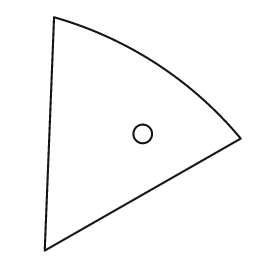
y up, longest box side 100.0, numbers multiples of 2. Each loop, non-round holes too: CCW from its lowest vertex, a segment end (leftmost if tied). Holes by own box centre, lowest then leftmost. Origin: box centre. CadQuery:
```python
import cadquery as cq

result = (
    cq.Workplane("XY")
    .moveTo(-42.0, -50.0)
    .lineTo(42.0, -2.0)
    .threePointArc((6.0, 30.0), (-38.0, 50.0))
    .close()
    .moveTo(0.0, 0.0)
    .circle(4.0)
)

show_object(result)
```